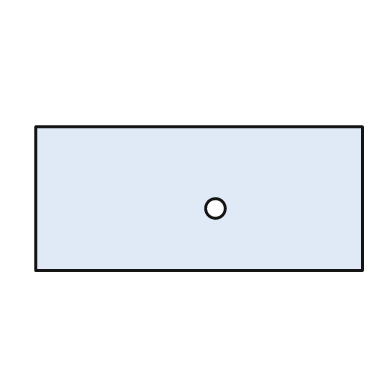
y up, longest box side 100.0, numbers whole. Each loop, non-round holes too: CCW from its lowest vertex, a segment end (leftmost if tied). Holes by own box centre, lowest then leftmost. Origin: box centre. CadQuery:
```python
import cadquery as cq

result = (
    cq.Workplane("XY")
    .moveTo(-50.0, -22.0)
    .lineTo(50.0, -22.0)
    .lineTo(50.0, 22.0)
    .lineTo(-50.0, 22.0)
    .close()
    .moveTo(5.0, -3.0)
    .circle(3.0)
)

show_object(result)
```